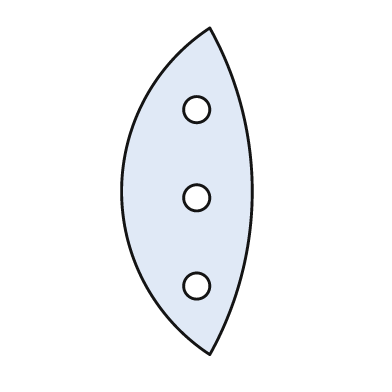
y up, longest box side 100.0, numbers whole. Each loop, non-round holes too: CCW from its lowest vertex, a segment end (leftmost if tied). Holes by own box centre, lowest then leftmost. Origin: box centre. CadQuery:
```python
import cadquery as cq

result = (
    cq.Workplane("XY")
    .moveTo(7.0, -50.0)
    .threePointArc((20.0, 0.0), (7.0, 50.0))
    .threePointArc((-20.0, 0.0), (7.0, -50.0))
    .close()
    .moveTo(3.0, -29.0)
    .circle(4.0)
    .moveTo(3.0, -2.0)
    .circle(4.0)
    .moveTo(3.0, 25.0)
    .circle(4.0)
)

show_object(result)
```